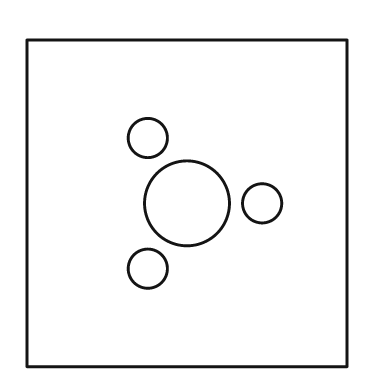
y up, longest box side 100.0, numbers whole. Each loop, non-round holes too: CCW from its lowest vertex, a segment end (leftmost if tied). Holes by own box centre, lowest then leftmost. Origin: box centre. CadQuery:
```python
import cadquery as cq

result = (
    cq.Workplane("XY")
    .moveTo(-49.0, -50.0)
    .lineTo(49.0, -50.0)
    .lineTo(49.0, 50.0)
    .lineTo(-49.0, 50.0)
    .close()
    .moveTo(-12.0, -20.0)
    .circle(6.0)
    .moveTo(0.0, 0.0)
    .circle(13.0)
    .moveTo(23.0, 0.0)
    .circle(6.0)
    .moveTo(-12.0, 20.0)
    .circle(6.0)
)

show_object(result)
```